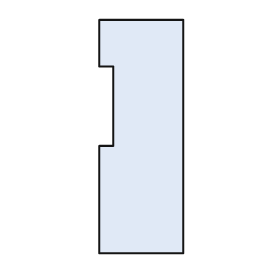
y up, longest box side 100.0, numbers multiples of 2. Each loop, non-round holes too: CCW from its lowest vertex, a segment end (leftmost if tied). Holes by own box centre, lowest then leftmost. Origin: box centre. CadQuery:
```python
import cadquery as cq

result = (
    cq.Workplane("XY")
    .moveTo(-18.0, -50.0)
    .lineTo(18.0, -50.0)
    .lineTo(18.0, 50.0)
    .lineTo(-18.0, 50.0)
    .lineTo(-18.0, 30.0)
    .lineTo(-12.0, 30.0)
    .lineTo(-12.0, -4.0)
    .lineTo(-18.0, -4.0)
    .close()
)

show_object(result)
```